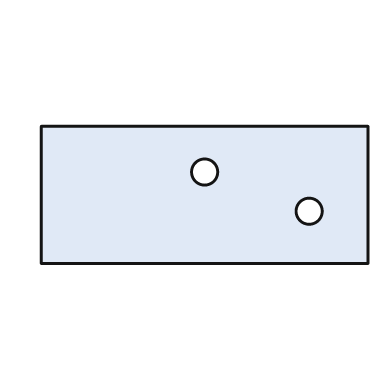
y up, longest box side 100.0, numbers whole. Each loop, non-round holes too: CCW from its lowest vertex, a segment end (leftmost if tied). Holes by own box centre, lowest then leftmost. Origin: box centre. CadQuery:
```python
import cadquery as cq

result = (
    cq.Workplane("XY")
    .moveTo(-50.0, -21.0)
    .lineTo(50.0, -21.0)
    .lineTo(50.0, 21.0)
    .lineTo(-50.0, 21.0)
    .close()
    .moveTo(32.0, -5.0)
    .circle(4.0)
    .moveTo(0.0, 7.0)
    .circle(4.0)
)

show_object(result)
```